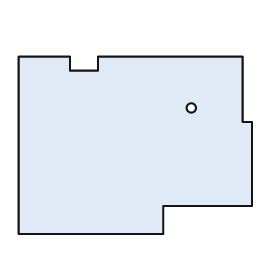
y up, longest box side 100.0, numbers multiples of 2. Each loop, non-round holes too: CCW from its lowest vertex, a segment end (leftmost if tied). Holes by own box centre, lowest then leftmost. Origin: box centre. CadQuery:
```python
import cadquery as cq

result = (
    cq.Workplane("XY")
    .moveTo(-50.0, -38.0)
    .lineTo(12.0, -38.0)
    .lineTo(12.0, -26.0)
    .lineTo(50.0, -26.0)
    .lineTo(50.0, 10.0)
    .lineTo(46.0, 10.0)
    .lineTo(46.0, 38.0)
    .lineTo(-16.0, 38.0)
    .lineTo(-16.0, 32.0)
    .lineTo(-28.0, 32.0)
    .lineTo(-28.0, 38.0)
    .lineTo(-50.0, 38.0)
    .close()
    .moveTo(24.0, 16.0)
    .circle(2.0)
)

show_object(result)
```